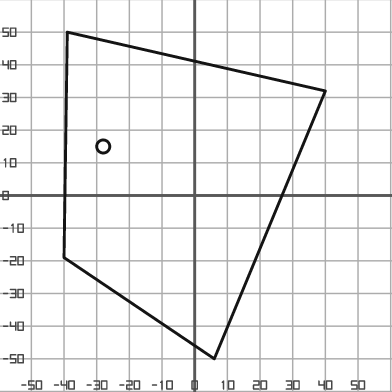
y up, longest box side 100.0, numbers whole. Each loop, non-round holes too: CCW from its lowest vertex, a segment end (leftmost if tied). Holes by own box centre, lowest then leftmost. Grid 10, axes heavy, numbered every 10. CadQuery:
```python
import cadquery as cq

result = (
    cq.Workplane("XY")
    .moveTo(6.0, -50.0)
    .lineTo(40.0, 32.0)
    .lineTo(-39.0, 50.0)
    .lineTo(-40.0, -19.0)
    .close()
    .moveTo(-28.0, 15.0)
    .circle(2.0)
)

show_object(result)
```